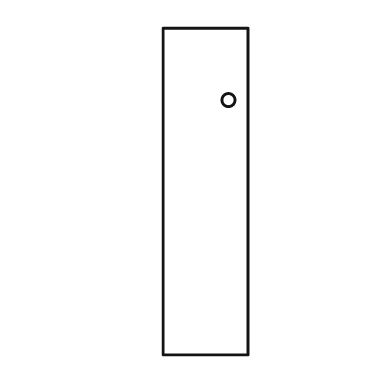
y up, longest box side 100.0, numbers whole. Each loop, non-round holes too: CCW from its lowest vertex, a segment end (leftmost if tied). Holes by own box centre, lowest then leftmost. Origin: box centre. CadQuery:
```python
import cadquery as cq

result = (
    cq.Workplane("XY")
    .moveTo(-13.0, -50.0)
    .lineTo(13.0, -50.0)
    .lineTo(13.0, 50.0)
    .lineTo(-13.0, 50.0)
    .close()
    .moveTo(7.0, 28.0)
    .circle(2.0)
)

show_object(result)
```